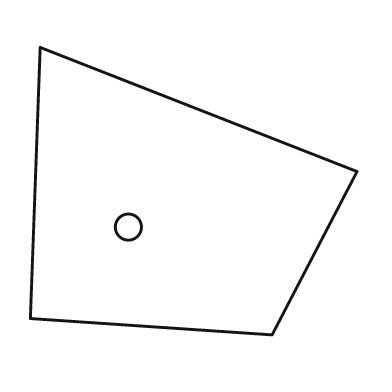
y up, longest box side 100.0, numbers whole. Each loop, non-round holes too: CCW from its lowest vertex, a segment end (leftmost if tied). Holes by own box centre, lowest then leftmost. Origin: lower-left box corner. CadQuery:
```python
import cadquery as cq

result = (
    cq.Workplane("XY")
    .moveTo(74.0, 0.0)
    .lineTo(100.0, 50.0)
    .lineTo(3.0, 88.0)
    .lineTo(0.0, 5.0)
    .close()
    .moveTo(30.0, 33.0)
    .circle(4.0)
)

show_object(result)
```